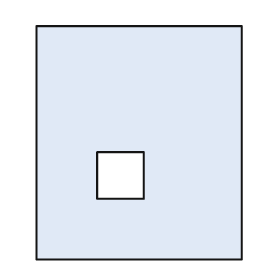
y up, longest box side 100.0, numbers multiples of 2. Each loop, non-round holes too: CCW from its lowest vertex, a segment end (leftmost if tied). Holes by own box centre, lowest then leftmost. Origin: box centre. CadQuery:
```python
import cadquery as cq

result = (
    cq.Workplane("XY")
    .moveTo(-44.0, -50.0)
    .lineTo(44.0, -50.0)
    .lineTo(44.0, 50.0)
    .lineTo(-44.0, 50.0)
    .close()
    .moveTo(-18.0, -24.0)
    .lineTo(2.0, -24.0)
    .lineTo(2.0, -4.0)
    .lineTo(-18.0, -4.0)
    .close()
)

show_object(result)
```